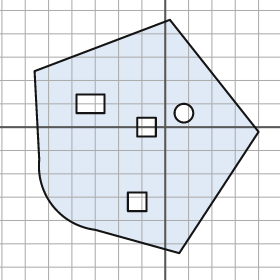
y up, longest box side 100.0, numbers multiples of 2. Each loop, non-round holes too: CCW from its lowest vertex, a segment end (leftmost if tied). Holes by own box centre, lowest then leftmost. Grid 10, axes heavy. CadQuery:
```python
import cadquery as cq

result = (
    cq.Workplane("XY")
    .moveTo(6.0, -54.0)
    .lineTo(40.0, -2.0)
    .lineTo(2.0, 46.0)
    .lineTo(-56.0, 24.0)
    .lineTo(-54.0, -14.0)
    .threePointArc((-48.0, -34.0), (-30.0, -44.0))
    .close()
    .moveTo(-16.0, -36.0)
    .lineTo(-8.0, -36.0)
    .lineTo(-8.0, -28.0)
    .lineTo(-16.0, -28.0)
    .close()
    .moveTo(-12.0, -4.0)
    .lineTo(-4.0, -4.0)
    .lineTo(-4.0, 4.0)
    .lineTo(-12.0, 4.0)
    .close()
    .moveTo(8.0, 6.0)
    .circle(4.0)
    .moveTo(-38.0, 6.0)
    .lineTo(-26.0, 6.0)
    .lineTo(-26.0, 14.0)
    .lineTo(-38.0, 14.0)
    .close()
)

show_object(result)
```